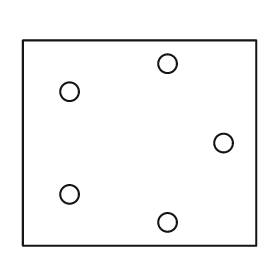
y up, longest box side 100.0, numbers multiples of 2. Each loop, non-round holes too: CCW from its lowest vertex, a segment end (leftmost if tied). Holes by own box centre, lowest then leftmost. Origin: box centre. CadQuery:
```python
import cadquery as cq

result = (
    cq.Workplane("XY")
    .moveTo(-50.0, -44.0)
    .lineTo(50.0, -44.0)
    .lineTo(50.0, 44.0)
    .lineTo(-50.0, 44.0)
    .close()
    .moveTo(12.0, -34.0)
    .circle(4.0)
    .moveTo(-30.0, -22.0)
    .circle(4.0)
    .moveTo(36.0, 0.0)
    .circle(4.0)
    .moveTo(-30.0, 22.0)
    .circle(4.0)
    .moveTo(12.0, 34.0)
    .circle(4.0)
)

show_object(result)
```